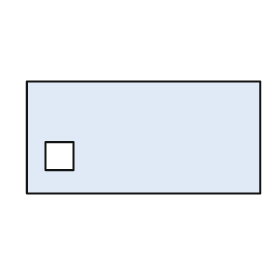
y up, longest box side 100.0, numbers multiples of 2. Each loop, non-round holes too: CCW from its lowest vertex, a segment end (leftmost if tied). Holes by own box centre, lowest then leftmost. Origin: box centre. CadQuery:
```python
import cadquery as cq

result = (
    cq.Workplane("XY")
    .moveTo(-50.0, -24.0)
    .lineTo(50.0, -24.0)
    .lineTo(50.0, 24.0)
    .lineTo(-50.0, 24.0)
    .close()
    .moveTo(-42.0, -14.0)
    .lineTo(-30.0, -14.0)
    .lineTo(-30.0, -2.0)
    .lineTo(-42.0, -2.0)
    .close()
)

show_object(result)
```